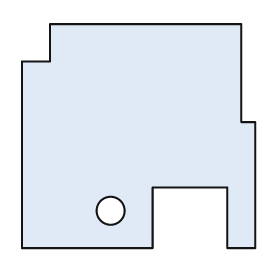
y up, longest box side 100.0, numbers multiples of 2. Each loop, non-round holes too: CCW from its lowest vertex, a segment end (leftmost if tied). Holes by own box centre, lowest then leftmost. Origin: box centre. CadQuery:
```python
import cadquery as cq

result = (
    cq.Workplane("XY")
    .moveTo(-50.0, -48.0)
    .lineTo(6.0, -48.0)
    .lineTo(6.0, -22.0)
    .lineTo(38.0, -22.0)
    .lineTo(38.0, -48.0)
    .lineTo(50.0, -48.0)
    .lineTo(50.0, 6.0)
    .lineTo(44.0, 6.0)
    .lineTo(44.0, 48.0)
    .lineTo(-38.0, 48.0)
    .lineTo(-38.0, 32.0)
    .lineTo(-50.0, 32.0)
    .close()
    .moveTo(-12.0, -32.0)
    .circle(6.0)
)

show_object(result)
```